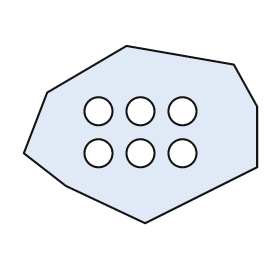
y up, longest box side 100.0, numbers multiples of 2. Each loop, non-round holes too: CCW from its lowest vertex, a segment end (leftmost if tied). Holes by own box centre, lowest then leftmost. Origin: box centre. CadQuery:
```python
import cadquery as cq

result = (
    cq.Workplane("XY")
    .moveTo(2.0, -38.0)
    .lineTo(50.0, -14.0)
    .lineTo(50.0, 12.0)
    .lineTo(40.0, 30.0)
    .lineTo(-6.0, 38.0)
    .lineTo(-40.0, 18.0)
    .lineTo(-50.0, -8.0)
    .lineTo(-32.0, -22.0)
    .close()
    .moveTo(-18.0, -8.0)
    .circle(6.0)
    .moveTo(0.0, -8.0)
    .circle(6.0)
    .moveTo(18.0, -8.0)
    .circle(6.0)
    .moveTo(-18.0, 10.0)
    .circle(6.0)
    .moveTo(0.0, 10.0)
    .circle(6.0)
    .moveTo(18.0, 10.0)
    .circle(6.0)
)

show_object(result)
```